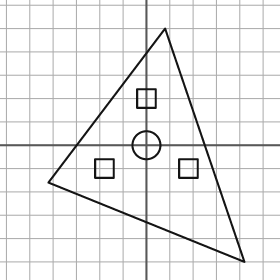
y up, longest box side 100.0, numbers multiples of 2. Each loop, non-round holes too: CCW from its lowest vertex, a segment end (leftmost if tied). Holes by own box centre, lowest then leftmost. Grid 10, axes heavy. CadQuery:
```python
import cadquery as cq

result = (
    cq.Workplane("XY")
    .moveTo(42.0, -50.0)
    .lineTo(8.0, 50.0)
    .lineTo(-42.0, -16.0)
    .close()
    .moveTo(-22.0, -14.0)
    .lineTo(-14.0, -14.0)
    .lineTo(-14.0, -6.0)
    .lineTo(-22.0, -6.0)
    .close()
    .moveTo(14.0, -14.0)
    .lineTo(22.0, -14.0)
    .lineTo(22.0, -6.0)
    .lineTo(14.0, -6.0)
    .close()
    .moveTo(0.0, 0.0)
    .circle(6.0)
    .moveTo(-4.0, 16.0)
    .lineTo(4.0, 16.0)
    .lineTo(4.0, 24.0)
    .lineTo(-4.0, 24.0)
    .close()
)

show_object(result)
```